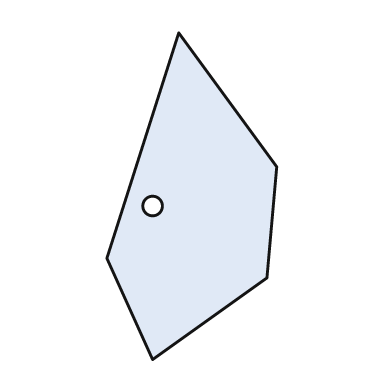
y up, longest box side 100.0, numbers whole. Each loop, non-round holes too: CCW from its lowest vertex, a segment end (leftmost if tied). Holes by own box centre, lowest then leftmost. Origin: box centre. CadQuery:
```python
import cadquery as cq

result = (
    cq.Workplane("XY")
    .moveTo(-12.0, -50.0)
    .lineTo(23.0, -25.0)
    .lineTo(26.0, 9.0)
    .lineTo(-4.0, 50.0)
    .lineTo(-26.0, -19.0)
    .close()
    .moveTo(-12.0, -3.0)
    .circle(3.0)
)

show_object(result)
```